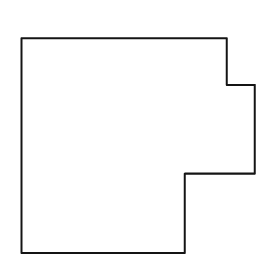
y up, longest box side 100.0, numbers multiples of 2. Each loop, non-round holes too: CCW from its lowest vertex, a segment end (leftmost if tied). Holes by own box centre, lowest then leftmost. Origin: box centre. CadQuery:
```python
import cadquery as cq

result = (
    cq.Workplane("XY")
    .moveTo(-50.0, -46.0)
    .lineTo(20.0, -46.0)
    .lineTo(20.0, -12.0)
    .lineTo(50.0, -12.0)
    .lineTo(50.0, 26.0)
    .lineTo(38.0, 26.0)
    .lineTo(38.0, 46.0)
    .lineTo(-50.0, 46.0)
    .close()
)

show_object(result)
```